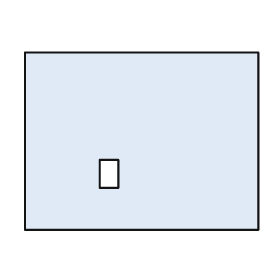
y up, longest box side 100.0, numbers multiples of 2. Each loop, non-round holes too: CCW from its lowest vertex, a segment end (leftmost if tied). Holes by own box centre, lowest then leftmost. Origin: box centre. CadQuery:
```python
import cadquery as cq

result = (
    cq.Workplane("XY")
    .moveTo(-50.0, -38.0)
    .lineTo(50.0, -38.0)
    .lineTo(50.0, 38.0)
    .lineTo(-50.0, 38.0)
    .close()
    .moveTo(-18.0, -20.0)
    .lineTo(-10.0, -20.0)
    .lineTo(-10.0, -8.0)
    .lineTo(-18.0, -8.0)
    .close()
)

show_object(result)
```